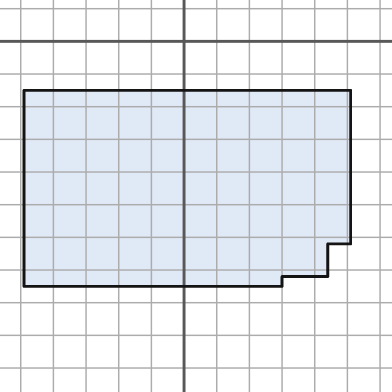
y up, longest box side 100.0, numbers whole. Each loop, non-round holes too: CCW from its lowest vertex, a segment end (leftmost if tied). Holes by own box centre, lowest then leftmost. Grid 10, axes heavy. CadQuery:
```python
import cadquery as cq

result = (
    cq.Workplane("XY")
    .moveTo(-49.0, -75.0)
    .lineTo(30.0, -75.0)
    .lineTo(30.0, -72.0)
    .lineTo(44.0, -72.0)
    .lineTo(44.0, -62.0)
    .lineTo(51.0, -62.0)
    .lineTo(51.0, -15.0)
    .lineTo(-49.0, -15.0)
    .close()
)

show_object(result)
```